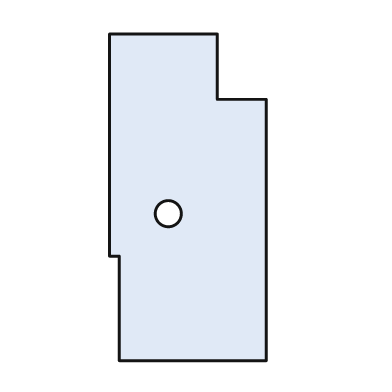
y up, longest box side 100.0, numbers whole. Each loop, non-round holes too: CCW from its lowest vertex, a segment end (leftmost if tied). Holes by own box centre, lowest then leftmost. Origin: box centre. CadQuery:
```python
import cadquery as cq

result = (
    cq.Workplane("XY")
    .moveTo(-21.0, -50.0)
    .lineTo(24.0, -50.0)
    .lineTo(24.0, 30.0)
    .lineTo(9.0, 30.0)
    .lineTo(9.0, 50.0)
    .lineTo(-24.0, 50.0)
    .lineTo(-24.0, -18.0)
    .lineTo(-21.0, -18.0)
    .close()
    .moveTo(-6.0, -5.0)
    .circle(4.0)
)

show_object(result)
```